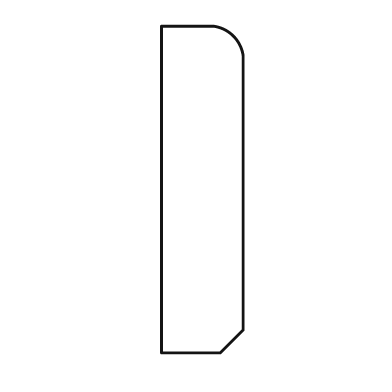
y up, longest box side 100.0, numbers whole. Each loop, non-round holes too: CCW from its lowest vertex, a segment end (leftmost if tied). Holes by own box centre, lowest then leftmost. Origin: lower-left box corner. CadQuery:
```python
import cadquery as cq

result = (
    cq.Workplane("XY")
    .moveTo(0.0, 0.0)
    .lineTo(18.0, 0.0)
    .lineTo(25.0, 7.0)
    .lineTo(25.0, 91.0)
    .threePointArc((22.0, 97.0), (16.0, 100.0))
    .lineTo(0.0, 100.0)
    .close()
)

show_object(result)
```